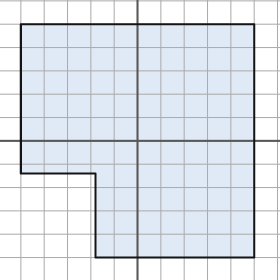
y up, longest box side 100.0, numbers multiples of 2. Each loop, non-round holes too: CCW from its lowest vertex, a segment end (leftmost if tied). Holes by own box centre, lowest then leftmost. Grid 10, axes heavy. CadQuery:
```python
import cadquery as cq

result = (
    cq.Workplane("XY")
    .moveTo(-18.0, -50.0)
    .lineTo(50.0, -50.0)
    .lineTo(50.0, 50.0)
    .lineTo(-50.0, 50.0)
    .lineTo(-50.0, -14.0)
    .lineTo(-18.0, -14.0)
    .close()
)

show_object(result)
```